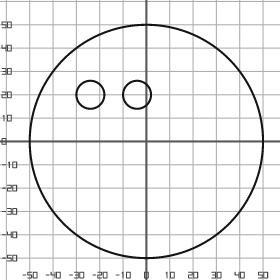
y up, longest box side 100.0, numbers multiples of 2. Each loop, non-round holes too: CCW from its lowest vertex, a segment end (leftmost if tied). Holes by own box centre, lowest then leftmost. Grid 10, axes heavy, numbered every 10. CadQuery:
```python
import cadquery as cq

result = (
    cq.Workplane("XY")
    .moveTo(0.0, 0.0)
    .circle(50.0)
    .moveTo(-24.0, 20.0)
    .circle(6.0)
    .moveTo(-4.0, 20.0)
    .circle(6.0)
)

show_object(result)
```